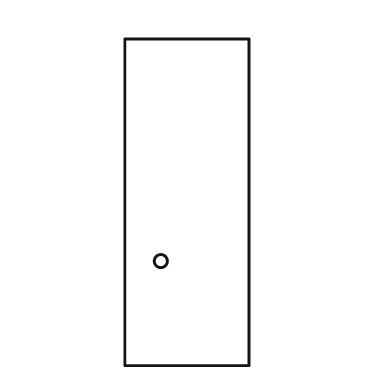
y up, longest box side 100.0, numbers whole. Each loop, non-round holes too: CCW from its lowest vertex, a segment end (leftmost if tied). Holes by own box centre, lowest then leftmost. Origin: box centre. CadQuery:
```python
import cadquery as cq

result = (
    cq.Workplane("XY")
    .moveTo(-19.0, -50.0)
    .lineTo(19.0, -50.0)
    .lineTo(19.0, 50.0)
    .lineTo(-19.0, 50.0)
    .close()
    .moveTo(-8.0, -18.0)
    .circle(2.0)
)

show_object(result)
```